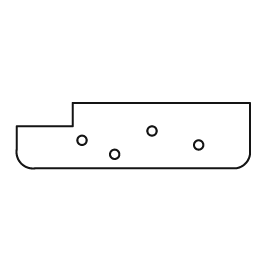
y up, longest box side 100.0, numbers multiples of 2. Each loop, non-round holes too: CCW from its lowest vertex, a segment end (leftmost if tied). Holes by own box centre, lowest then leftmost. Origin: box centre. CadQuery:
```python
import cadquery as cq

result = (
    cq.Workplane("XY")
    .moveTo(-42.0, -14.0)
    .lineTo(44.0, -14.0)
    .threePointArc((48.0, -12.0), (50.0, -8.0))
    .lineTo(50.0, 14.0)
    .lineTo(-26.0, 14.0)
    .lineTo(-26.0, 4.0)
    .lineTo(-50.0, 4.0)
    .lineTo(-50.0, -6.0)
    .threePointArc((-48.0, -12.0), (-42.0, -14.0))
    .close()
    .moveTo(-8.0, -8.0)
    .circle(2.0)
    .moveTo(28.0, -4.0)
    .circle(2.0)
    .moveTo(-22.0, -2.0)
    .circle(2.0)
    .moveTo(8.0, 2.0)
    .circle(2.0)
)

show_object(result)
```